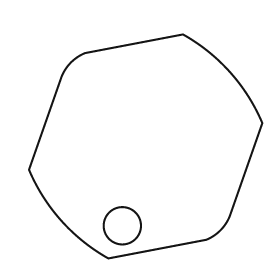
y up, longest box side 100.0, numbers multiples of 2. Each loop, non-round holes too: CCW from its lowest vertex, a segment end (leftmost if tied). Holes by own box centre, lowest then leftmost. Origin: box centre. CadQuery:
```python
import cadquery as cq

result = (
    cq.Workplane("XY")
    .moveTo(-16.0, -48.0)
    .lineTo(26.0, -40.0)
    .threePointArc((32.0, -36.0), (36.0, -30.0))
    .lineTo(50.0, 10.0)
    .threePointArc((36.0, 32.0), (16.0, 48.0))
    .lineTo(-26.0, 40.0)
    .threePointArc((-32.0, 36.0), (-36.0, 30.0))
    .lineTo(-50.0, -10.0)
    .threePointArc((-36.0, -32.0), (-16.0, -48.0))
    .close()
    .moveTo(-10.0, -34.0)
    .circle(8.0)
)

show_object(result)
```